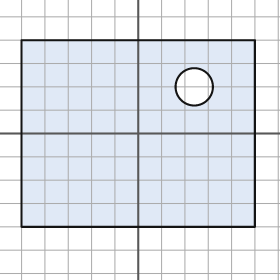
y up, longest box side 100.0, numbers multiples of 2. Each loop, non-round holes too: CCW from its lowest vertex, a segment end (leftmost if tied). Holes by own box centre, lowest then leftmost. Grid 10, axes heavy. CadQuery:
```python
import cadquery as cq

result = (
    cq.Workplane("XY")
    .moveTo(-50.0, -40.0)
    .lineTo(50.0, -40.0)
    .lineTo(50.0, 40.0)
    .lineTo(-50.0, 40.0)
    .close()
    .moveTo(24.0, 20.0)
    .circle(8.0)
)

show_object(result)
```